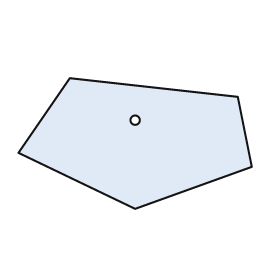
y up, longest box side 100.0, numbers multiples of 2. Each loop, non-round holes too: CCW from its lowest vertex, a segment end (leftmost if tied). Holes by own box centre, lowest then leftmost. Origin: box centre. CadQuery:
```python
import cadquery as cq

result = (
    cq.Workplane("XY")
    .moveTo(0.0, -28.0)
    .lineTo(50.0, -10.0)
    .lineTo(44.0, 20.0)
    .lineTo(-28.0, 28.0)
    .lineTo(-50.0, -4.0)
    .close()
    .moveTo(0.0, 10.0)
    .circle(2.0)
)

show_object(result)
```